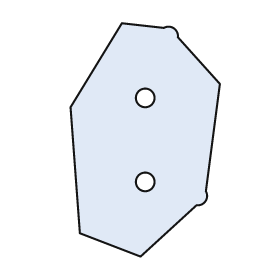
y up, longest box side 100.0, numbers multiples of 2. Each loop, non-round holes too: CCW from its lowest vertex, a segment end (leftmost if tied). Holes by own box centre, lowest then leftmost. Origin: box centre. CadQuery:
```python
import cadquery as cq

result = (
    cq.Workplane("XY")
    .moveTo(-2.0, -50.0)
    .lineTo(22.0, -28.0)
    .threePointArc((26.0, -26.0), (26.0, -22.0))
    .lineTo(32.0, 24.0)
    .lineTo(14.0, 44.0)
    .threePointArc((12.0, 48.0), (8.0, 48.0))
    .lineTo(-10.0, 50.0)
    .lineTo(-32.0, 14.0)
    .lineTo(-28.0, -40.0)
    .close()
    .moveTo(0.0, -18.0)
    .circle(4.0)
    .moveTo(0.0, 18.0)
    .circle(4.0)
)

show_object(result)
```